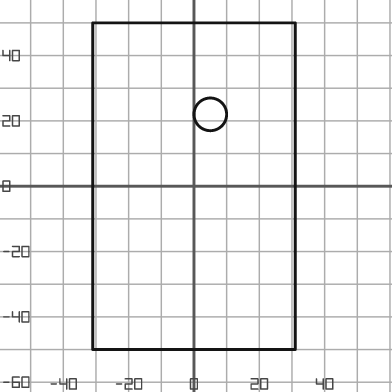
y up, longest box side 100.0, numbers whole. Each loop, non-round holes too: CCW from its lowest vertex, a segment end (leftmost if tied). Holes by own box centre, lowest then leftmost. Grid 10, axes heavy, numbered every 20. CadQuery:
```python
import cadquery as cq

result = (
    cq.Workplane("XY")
    .moveTo(-31.0, -50.0)
    .lineTo(31.0, -50.0)
    .lineTo(31.0, 50.0)
    .lineTo(-31.0, 50.0)
    .close()
    .moveTo(5.0, 22.0)
    .circle(5.0)
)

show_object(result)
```